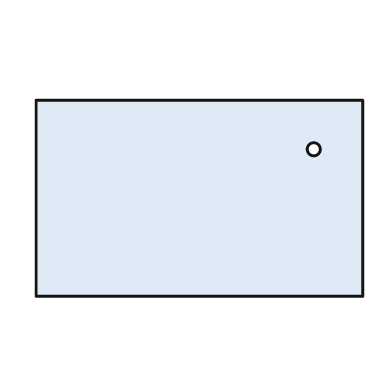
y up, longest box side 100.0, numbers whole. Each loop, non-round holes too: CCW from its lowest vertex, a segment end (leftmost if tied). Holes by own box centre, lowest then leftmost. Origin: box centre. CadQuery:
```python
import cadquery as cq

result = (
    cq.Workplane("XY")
    .moveTo(-50.0, -30.0)
    .lineTo(50.0, -30.0)
    .lineTo(50.0, 30.0)
    .lineTo(-50.0, 30.0)
    .close()
    .moveTo(35.0, 15.0)
    .circle(2.0)
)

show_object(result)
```